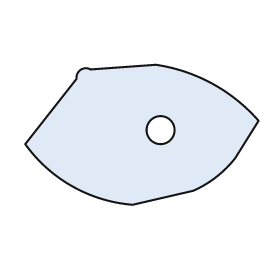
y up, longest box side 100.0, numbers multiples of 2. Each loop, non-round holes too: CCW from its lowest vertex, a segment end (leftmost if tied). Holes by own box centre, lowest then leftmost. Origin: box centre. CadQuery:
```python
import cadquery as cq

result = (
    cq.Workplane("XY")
    .moveTo(-4.0, -30.0)
    .lineTo(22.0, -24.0)
    .threePointArc((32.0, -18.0), (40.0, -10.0))
    .lineTo(50.0, 6.0)
    .threePointArc((30.0, 22.0), (6.0, 30.0))
    .lineTo(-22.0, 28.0)
    .threePointArc((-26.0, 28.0), (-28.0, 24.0))
    .lineTo(-50.0, -4.0)
    .threePointArc((-30.0, -22.0), (-4.0, -30.0))
    .close()
    .moveTo(8.0, 2.0)
    .circle(6.0)
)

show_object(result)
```